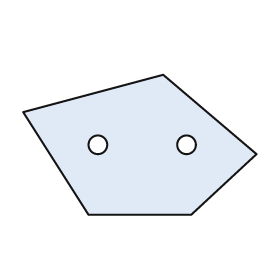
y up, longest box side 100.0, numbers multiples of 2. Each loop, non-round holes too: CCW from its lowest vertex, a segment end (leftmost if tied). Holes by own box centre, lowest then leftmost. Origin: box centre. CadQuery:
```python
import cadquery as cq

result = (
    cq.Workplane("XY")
    .moveTo(-22.0, -30.0)
    .lineTo(22.0, -30.0)
    .lineTo(50.0, -4.0)
    .lineTo(10.0, 30.0)
    .lineTo(-50.0, 14.0)
    .close()
    .moveTo(-18.0, 0.0)
    .circle(4.0)
    .moveTo(20.0, 0.0)
    .circle(4.0)
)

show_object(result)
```